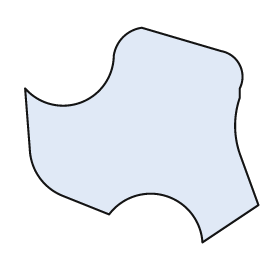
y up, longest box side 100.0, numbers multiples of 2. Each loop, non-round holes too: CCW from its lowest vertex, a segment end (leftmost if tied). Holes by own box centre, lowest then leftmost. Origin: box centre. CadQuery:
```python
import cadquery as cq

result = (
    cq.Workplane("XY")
    .moveTo(26.0, -46.0)
    .lineTo(50.0, -30.0)
    .lineTo(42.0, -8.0)
    .threePointArc((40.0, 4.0), (42.0, 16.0))
    .lineTo(42.0, 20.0)
    .threePointArc((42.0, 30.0), (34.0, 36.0))
    .lineTo(0.0, 46.0)
    .threePointArc((-8.0, 42.0), (-12.0, 34.0))
    .threePointArc((-26.0, 14.0), (-50.0, 20.0))
    .lineTo(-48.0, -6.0)
    .threePointArc((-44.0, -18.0), (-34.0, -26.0))
    .lineTo(-14.0, -34.0)
    .threePointArc((10.0, -26.0), (26.0, -46.0))
    .close()
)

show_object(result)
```